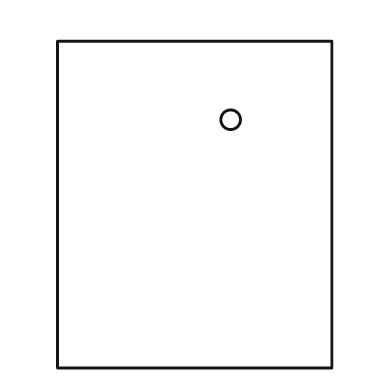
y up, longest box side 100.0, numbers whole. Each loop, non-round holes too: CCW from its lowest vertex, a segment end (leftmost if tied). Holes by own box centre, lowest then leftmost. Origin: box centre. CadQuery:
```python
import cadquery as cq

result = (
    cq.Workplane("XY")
    .moveTo(-42.0, -50.0)
    .lineTo(42.0, -50.0)
    .lineTo(42.0, 50.0)
    .lineTo(-42.0, 50.0)
    .close()
    .moveTo(11.0, 26.0)
    .circle(3.0)
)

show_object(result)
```